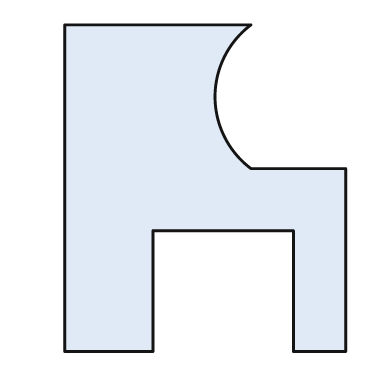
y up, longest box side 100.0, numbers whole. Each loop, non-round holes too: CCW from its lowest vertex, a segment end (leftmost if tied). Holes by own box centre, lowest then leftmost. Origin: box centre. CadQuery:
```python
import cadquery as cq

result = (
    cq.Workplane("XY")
    .moveTo(-43.0, -50.0)
    .lineTo(-16.0, -50.0)
    .lineTo(-16.0, -13.0)
    .lineTo(27.0, -13.0)
    .lineTo(27.0, -50.0)
    .lineTo(43.0, -50.0)
    .lineTo(43.0, 6.0)
    .lineTo(14.0, 6.0)
    .threePointArc((3.0, 28.0), (14.0, 50.0))
    .lineTo(-43.0, 50.0)
    .close()
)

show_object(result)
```